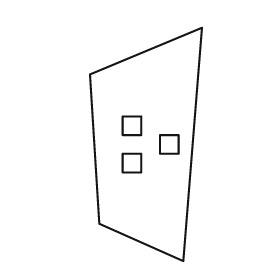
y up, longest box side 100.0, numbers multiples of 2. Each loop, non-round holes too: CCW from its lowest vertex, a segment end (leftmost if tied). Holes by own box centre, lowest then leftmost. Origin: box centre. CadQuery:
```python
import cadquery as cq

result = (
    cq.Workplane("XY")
    .moveTo(16.0, -50.0)
    .lineTo(24.0, 50.0)
    .lineTo(-24.0, 30.0)
    .lineTo(-20.0, -34.0)
    .close()
    .moveTo(-10.0, -12.0)
    .lineTo(-2.0, -12.0)
    .lineTo(-2.0, -4.0)
    .lineTo(-10.0, -4.0)
    .close()
    .moveTo(6.0, -4.0)
    .lineTo(14.0, -4.0)
    .lineTo(14.0, 4.0)
    .lineTo(6.0, 4.0)
    .close()
    .moveTo(-10.0, 4.0)
    .lineTo(-2.0, 4.0)
    .lineTo(-2.0, 12.0)
    .lineTo(-10.0, 12.0)
    .close()
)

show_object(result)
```